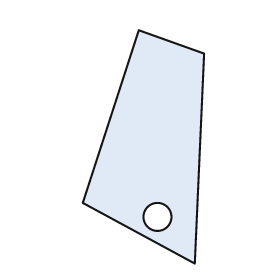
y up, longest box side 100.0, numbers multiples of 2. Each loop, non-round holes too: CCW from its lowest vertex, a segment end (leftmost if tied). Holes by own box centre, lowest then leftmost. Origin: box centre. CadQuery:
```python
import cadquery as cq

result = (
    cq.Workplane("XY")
    .moveTo(22.0, -50.0)
    .lineTo(26.0, 40.0)
    .lineTo(-2.0, 50.0)
    .lineTo(-26.0, -24.0)
    .close()
    .moveTo(6.0, -30.0)
    .circle(6.0)
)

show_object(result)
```